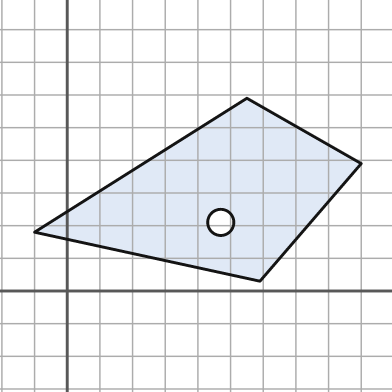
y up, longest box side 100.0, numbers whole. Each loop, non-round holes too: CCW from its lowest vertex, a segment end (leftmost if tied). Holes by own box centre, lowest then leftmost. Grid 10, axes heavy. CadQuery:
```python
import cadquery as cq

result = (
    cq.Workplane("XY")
    .moveTo(59.0, 3.0)
    .lineTo(90.0, 39.0)
    .lineTo(55.0, 59.0)
    .lineTo(-10.0, 18.0)
    .close()
    .moveTo(47.0, 21.0)
    .circle(4.0)
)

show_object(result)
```